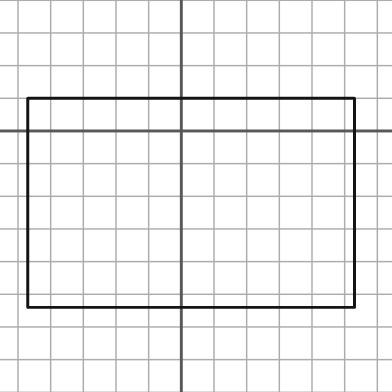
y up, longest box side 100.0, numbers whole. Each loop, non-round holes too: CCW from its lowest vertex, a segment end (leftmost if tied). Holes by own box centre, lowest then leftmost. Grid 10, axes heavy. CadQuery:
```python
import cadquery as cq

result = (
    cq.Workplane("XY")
    .moveTo(-47.0, -54.0)
    .lineTo(53.0, -54.0)
    .lineTo(53.0, 10.0)
    .lineTo(-47.0, 10.0)
    .close()
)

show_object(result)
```